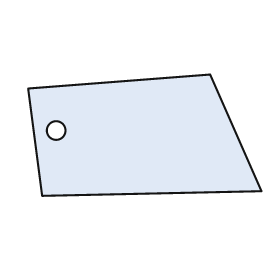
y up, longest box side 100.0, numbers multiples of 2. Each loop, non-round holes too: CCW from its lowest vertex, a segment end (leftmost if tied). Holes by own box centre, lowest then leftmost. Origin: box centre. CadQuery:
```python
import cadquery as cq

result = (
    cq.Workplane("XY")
    .moveTo(-44.0, -26.0)
    .lineTo(50.0, -24.0)
    .lineTo(28.0, 26.0)
    .lineTo(-50.0, 20.0)
    .close()
    .moveTo(-38.0, 2.0)
    .circle(4.0)
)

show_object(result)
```